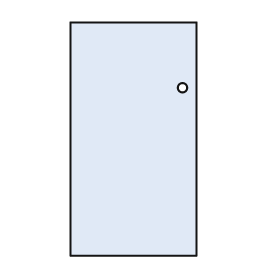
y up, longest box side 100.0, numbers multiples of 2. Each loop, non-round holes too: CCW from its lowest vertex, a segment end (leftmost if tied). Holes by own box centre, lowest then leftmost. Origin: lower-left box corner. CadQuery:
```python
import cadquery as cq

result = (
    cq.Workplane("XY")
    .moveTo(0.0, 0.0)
    .lineTo(54.0, 0.0)
    .lineTo(54.0, 100.0)
    .lineTo(0.0, 100.0)
    .close()
    .moveTo(48.0, 72.0)
    .circle(2.0)
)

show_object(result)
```